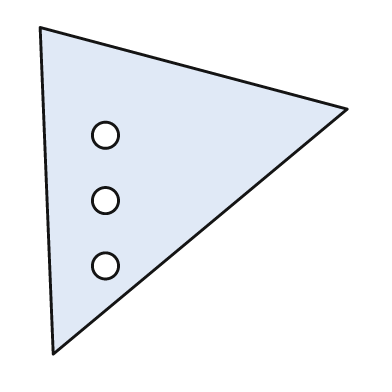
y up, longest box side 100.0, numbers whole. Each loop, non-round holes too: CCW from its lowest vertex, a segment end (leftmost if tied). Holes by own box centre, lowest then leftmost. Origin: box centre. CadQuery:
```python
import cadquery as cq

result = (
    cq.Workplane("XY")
    .moveTo(-43.0, -50.0)
    .lineTo(47.0, 25.0)
    .lineTo(-47.0, 50.0)
    .close()
    .moveTo(-27.0, -23.0)
    .circle(4.0)
    .moveTo(-27.0, -3.0)
    .circle(4.0)
    .moveTo(-27.0, 17.0)
    .circle(4.0)
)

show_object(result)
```